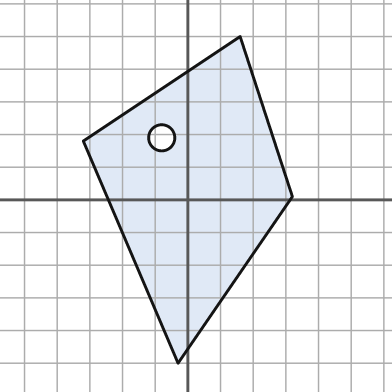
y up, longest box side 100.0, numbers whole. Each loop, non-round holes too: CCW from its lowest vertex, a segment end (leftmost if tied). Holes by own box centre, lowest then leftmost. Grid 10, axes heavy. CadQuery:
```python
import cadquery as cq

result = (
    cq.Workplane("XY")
    .moveTo(-3.0, -50.0)
    .lineTo(32.0, 1.0)
    .lineTo(16.0, 50.0)
    .lineTo(-32.0, 18.0)
    .close()
    .moveTo(-8.0, 19.0)
    .circle(4.0)
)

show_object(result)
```